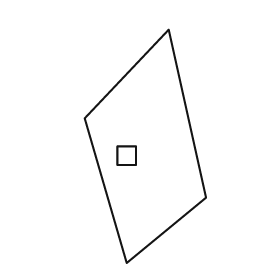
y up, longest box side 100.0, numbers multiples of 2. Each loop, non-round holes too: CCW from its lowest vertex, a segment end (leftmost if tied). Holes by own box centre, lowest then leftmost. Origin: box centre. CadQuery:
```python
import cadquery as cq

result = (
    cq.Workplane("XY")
    .moveTo(-8.0, -50.0)
    .lineTo(26.0, -22.0)
    .lineTo(10.0, 50.0)
    .lineTo(-26.0, 12.0)
    .close()
    .moveTo(-12.0, -8.0)
    .lineTo(-4.0, -8.0)
    .lineTo(-4.0, 0.0)
    .lineTo(-12.0, 0.0)
    .close()
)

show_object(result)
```